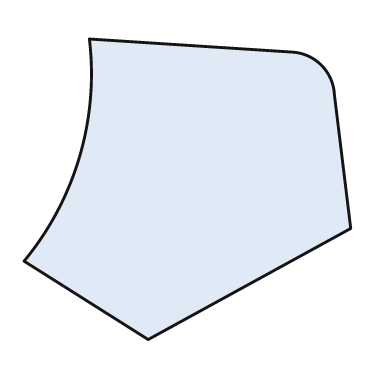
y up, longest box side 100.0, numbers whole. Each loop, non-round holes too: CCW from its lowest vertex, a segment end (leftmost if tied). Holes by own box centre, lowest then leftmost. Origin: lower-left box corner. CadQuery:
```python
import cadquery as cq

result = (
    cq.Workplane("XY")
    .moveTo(38.0, 0.0)
    .lineTo(100.0, 34.0)
    .lineTo(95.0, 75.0)
    .threePointArc((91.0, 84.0), (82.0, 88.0))
    .lineTo(20.0, 92.0)
    .threePointArc((17.0, 56.0), (0.0, 24.0))
    .close()
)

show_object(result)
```